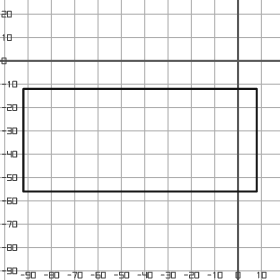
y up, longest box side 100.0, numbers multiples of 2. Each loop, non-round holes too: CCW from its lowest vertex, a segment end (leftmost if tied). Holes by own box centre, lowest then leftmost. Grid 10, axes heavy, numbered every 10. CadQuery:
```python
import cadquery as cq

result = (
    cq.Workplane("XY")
    .moveTo(-92.0, -56.0)
    .lineTo(8.0, -56.0)
    .lineTo(8.0, -12.0)
    .lineTo(-92.0, -12.0)
    .close()
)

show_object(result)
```